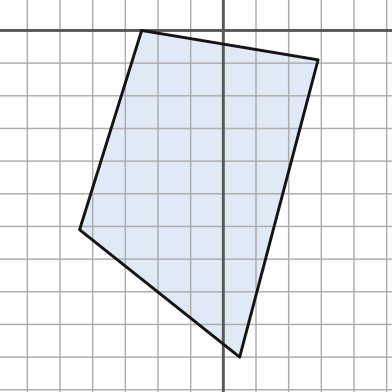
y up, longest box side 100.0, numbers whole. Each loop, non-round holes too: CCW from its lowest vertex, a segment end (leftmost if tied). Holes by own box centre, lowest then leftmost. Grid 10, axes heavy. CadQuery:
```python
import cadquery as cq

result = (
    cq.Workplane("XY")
    .moveTo(5.0, -100.0)
    .lineTo(29.0, -9.0)
    .lineTo(-25.0, 0.0)
    .lineTo(-44.0, -61.0)
    .close()
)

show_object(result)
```